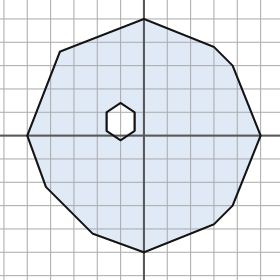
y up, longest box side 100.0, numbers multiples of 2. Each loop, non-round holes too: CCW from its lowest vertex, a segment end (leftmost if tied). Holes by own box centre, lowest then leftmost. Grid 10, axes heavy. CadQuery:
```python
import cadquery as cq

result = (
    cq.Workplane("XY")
    .moveTo(0.0, -50.0)
    .lineTo(30.0, -38.0)
    .lineTo(38.0, -30.0)
    .lineTo(50.0, 0.0)
    .lineTo(38.0, 30.0)
    .lineTo(30.0, 38.0)
    .lineTo(0.0, 50.0)
    .lineTo(-36.0, 36.0)
    .lineTo(-50.0, 0.0)
    .lineTo(-42.0, -22.0)
    .lineTo(-22.0, -42.0)
    .close()
    .moveTo(-10.0, -2.0)
    .lineTo(-4.0, 2.0)
    .lineTo(-4.0, 10.0)
    .lineTo(-10.0, 14.0)
    .lineTo(-16.0, 10.0)
    .lineTo(-16.0, 2.0)
    .close()
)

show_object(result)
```